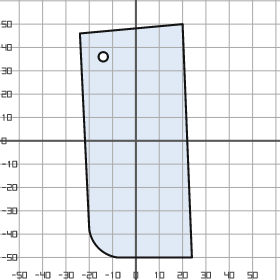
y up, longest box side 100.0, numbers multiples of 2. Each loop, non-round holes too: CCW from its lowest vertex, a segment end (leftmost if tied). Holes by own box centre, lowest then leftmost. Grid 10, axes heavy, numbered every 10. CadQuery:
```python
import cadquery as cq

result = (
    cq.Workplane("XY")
    .moveTo(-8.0, -50.0)
    .lineTo(24.0, -50.0)
    .lineTo(20.0, 50.0)
    .lineTo(-24.0, 46.0)
    .lineTo(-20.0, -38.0)
    .threePointArc((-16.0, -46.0), (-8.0, -50.0))
    .close()
    .moveTo(-14.0, 36.0)
    .circle(2.0)
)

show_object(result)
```